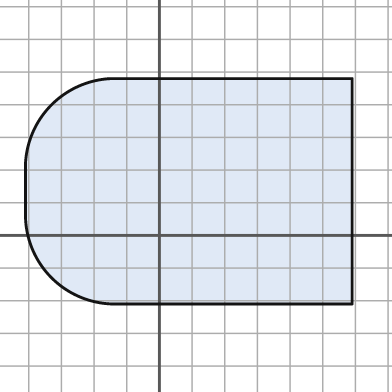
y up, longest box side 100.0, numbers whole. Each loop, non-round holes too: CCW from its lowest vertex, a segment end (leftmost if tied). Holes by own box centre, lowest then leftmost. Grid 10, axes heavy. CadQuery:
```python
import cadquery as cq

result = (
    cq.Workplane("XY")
    .moveTo(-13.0, -21.0)
    .lineTo(59.0, -21.0)
    .lineTo(59.0, 48.0)
    .lineTo(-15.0, 48.0)
    .threePointArc((-33.0, 40.0), (-41.0, 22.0))
    .lineTo(-41.0, 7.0)
    .threePointArc((-33.0, -13.0), (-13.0, -21.0))
    .close()
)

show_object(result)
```